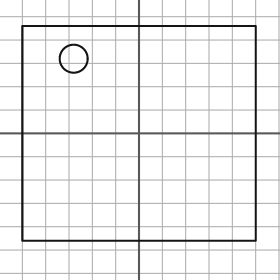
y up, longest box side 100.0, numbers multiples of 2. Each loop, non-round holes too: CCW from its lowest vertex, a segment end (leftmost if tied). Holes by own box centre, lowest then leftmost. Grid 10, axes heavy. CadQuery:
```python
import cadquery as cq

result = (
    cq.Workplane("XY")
    .moveTo(-50.0, -46.0)
    .lineTo(50.0, -46.0)
    .lineTo(50.0, 46.0)
    .lineTo(-50.0, 46.0)
    .close()
    .moveTo(-28.0, 32.0)
    .circle(6.0)
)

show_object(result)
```